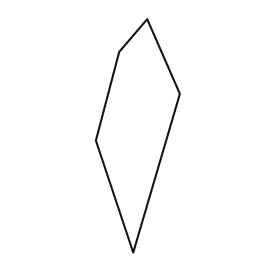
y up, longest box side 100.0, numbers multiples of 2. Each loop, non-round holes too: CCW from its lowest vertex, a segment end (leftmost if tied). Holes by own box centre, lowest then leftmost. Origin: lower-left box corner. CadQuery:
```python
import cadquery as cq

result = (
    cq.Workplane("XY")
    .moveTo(16.0, 0.0)
    .lineTo(36.0, 68.0)
    .lineTo(22.0, 100.0)
    .lineTo(10.0, 86.0)
    .lineTo(0.0, 48.0)
    .close()
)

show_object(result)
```